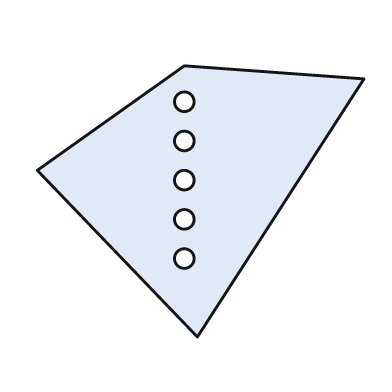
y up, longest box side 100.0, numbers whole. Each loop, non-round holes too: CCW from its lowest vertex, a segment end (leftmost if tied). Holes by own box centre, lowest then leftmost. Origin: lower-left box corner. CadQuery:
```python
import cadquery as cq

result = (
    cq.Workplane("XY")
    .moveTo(49.0, 0.0)
    .lineTo(100.0, 79.0)
    .lineTo(45.0, 83.0)
    .lineTo(0.0, 51.0)
    .close()
    .moveTo(45.0, 24.0)
    .circle(3.0)
    .moveTo(45.0, 36.0)
    .circle(3.0)
    .moveTo(45.0, 48.0)
    .circle(3.0)
    .moveTo(45.0, 60.0)
    .circle(3.0)
    .moveTo(45.0, 72.0)
    .circle(3.0)
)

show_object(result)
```